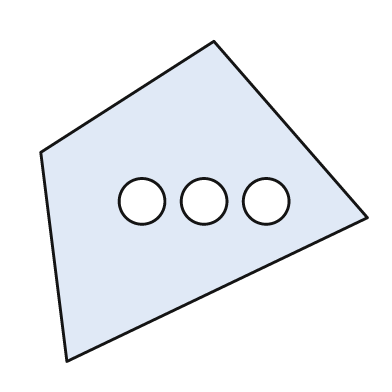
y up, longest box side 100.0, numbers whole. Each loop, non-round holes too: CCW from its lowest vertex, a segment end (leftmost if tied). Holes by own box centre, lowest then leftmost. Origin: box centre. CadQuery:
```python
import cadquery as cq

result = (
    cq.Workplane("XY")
    .moveTo(-42.0, -49.0)
    .lineTo(50.0, -5.0)
    .lineTo(3.0, 49.0)
    .lineTo(-50.0, 15.0)
    .close()
    .moveTo(-19.0, 0.0)
    .circle(7.0)
    .moveTo(0.0, 0.0)
    .circle(7.0)
    .moveTo(19.0, 0.0)
    .circle(7.0)
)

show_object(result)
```